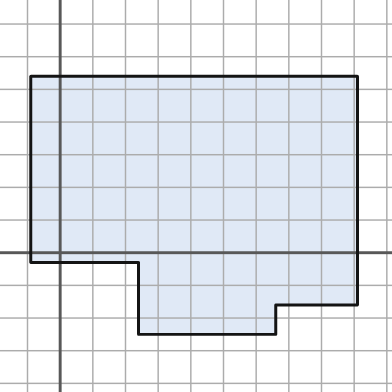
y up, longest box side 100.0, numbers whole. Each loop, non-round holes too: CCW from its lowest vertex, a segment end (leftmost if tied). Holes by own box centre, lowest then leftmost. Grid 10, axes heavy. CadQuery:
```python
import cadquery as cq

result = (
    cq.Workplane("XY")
    .moveTo(24.0, -25.0)
    .lineTo(66.0, -25.0)
    .lineTo(66.0, -16.0)
    .lineTo(91.0, -16.0)
    .lineTo(91.0, 54.0)
    .lineTo(-9.0, 54.0)
    .lineTo(-9.0, -3.0)
    .lineTo(24.0, -3.0)
    .close()
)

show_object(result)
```